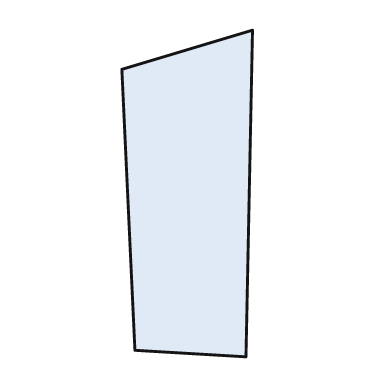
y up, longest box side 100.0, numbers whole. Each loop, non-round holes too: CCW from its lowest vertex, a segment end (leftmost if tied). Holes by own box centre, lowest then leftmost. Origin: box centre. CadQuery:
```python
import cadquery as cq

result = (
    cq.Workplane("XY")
    .moveTo(18.0, -50.0)
    .lineTo(20.0, 50.0)
    .lineTo(-20.0, 38.0)
    .lineTo(-16.0, -48.0)
    .close()
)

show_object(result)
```